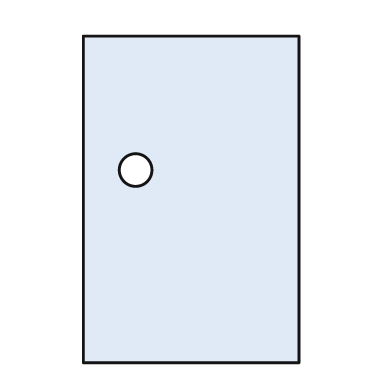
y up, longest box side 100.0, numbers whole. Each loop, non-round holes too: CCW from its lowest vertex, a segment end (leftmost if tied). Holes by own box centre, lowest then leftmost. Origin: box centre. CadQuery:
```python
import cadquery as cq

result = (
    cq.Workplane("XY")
    .moveTo(-33.0, -50.0)
    .lineTo(33.0, -50.0)
    .lineTo(33.0, 50.0)
    .lineTo(-33.0, 50.0)
    .close()
    .moveTo(-17.0, 9.0)
    .circle(5.0)
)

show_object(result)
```